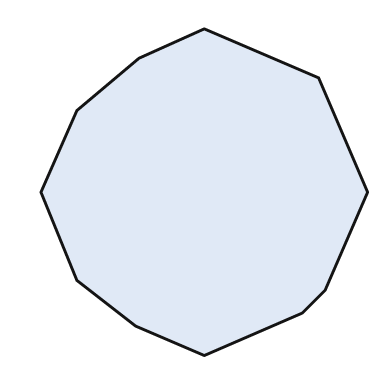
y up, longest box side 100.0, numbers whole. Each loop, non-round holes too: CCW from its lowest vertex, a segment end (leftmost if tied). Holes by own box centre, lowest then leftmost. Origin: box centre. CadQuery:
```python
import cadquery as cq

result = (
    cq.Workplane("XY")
    .moveTo(0.0, -50.0)
    .lineTo(30.0, -37.0)
    .lineTo(37.0, -30.0)
    .lineTo(50.0, 0.0)
    .lineTo(35.0, 35.0)
    .lineTo(0.0, 50.0)
    .lineTo(-20.0, 41.0)
    .lineTo(-39.0, 25.0)
    .lineTo(-50.0, 0.0)
    .lineTo(-39.0, -27.0)
    .lineTo(-21.0, -41.0)
    .close()
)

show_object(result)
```